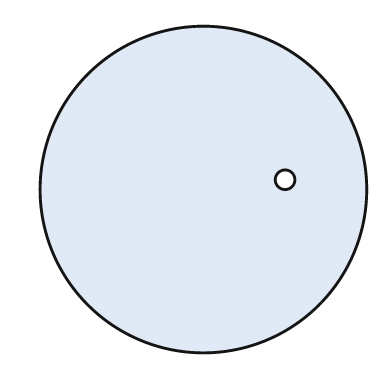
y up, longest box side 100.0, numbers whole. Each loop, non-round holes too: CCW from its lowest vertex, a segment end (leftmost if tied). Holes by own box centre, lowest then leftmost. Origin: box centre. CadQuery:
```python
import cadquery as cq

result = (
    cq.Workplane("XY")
    .moveTo(0.0, 0.0)
    .circle(50.0)
    .moveTo(25.0, 3.0)
    .circle(3.0)
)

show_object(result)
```